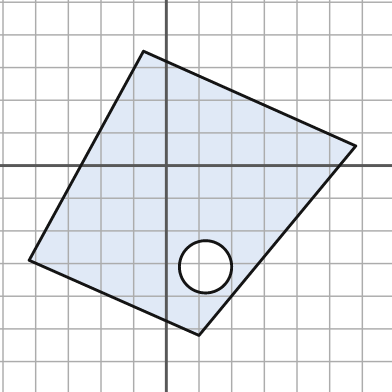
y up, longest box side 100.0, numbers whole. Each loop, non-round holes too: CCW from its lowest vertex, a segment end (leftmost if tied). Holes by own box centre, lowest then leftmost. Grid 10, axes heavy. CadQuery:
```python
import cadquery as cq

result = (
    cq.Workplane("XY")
    .moveTo(10.0, -52.0)
    .lineTo(58.0, 6.0)
    .lineTo(-7.0, 35.0)
    .lineTo(-42.0, -29.0)
    .close()
    .moveTo(12.0, -31.0)
    .circle(8.0)
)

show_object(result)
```